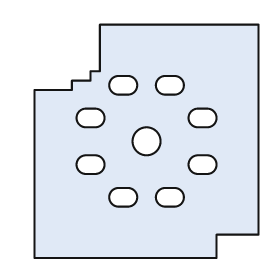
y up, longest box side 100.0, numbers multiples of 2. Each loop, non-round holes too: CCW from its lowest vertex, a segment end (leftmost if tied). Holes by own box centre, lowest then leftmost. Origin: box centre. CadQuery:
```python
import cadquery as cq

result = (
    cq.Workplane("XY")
    .moveTo(-48.0, -50.0)
    .lineTo(30.0, -50.0)
    .lineTo(30.0, -40.0)
    .lineTo(48.0, -40.0)
    .lineTo(48.0, 50.0)
    .lineTo(-20.0, 50.0)
    .lineTo(-20.0, 30.0)
    .lineTo(-24.0, 30.0)
    .lineTo(-24.0, 26.0)
    .lineTo(-32.0, 26.0)
    .lineTo(-32.0, 22.0)
    .lineTo(-48.0, 22.0)
    .close()
    .moveTo(-12.0, -28.0)
    .lineTo(-8.0, -28.0)
    .threePointArc((-4.0, -24.0), (-8.0, -20.0))
    .lineTo(-12.0, -20.0)
    .threePointArc((-16.0, -24.0), (-12.0, -28.0))
    .close()
    .moveTo(8.0, -28.0)
    .lineTo(12.0, -28.0)
    .threePointArc((16.0, -24.0), (12.0, -20.0))
    .lineTo(8.0, -20.0)
    .threePointArc((4.0, -24.0), (8.0, -28.0))
    .close()
    .moveTo(-26.0, -14.0)
    .lineTo(-22.0, -14.0)
    .threePointArc((-18.0, -10.0), (-22.0, -6.0))
    .lineTo(-26.0, -6.0)
    .threePointArc((-30.0, -10.0), (-26.0, -14.0))
    .close()
    .moveTo(22.0, -14.0)
    .lineTo(26.0, -14.0)
    .threePointArc((30.0, -10.0), (26.0, -6.0))
    .lineTo(22.0, -6.0)
    .threePointArc((18.0, -10.0), (22.0, -14.0))
    .close()
    .moveTo(0.0, 0.0)
    .circle(6.0)
    .moveTo(-26.0, 6.0)
    .lineTo(-22.0, 6.0)
    .threePointArc((-18.0, 10.0), (-22.0, 14.0))
    .lineTo(-26.0, 14.0)
    .threePointArc((-30.0, 10.0), (-26.0, 6.0))
    .close()
    .moveTo(22.0, 6.0)
    .lineTo(26.0, 6.0)
    .threePointArc((30.0, 10.0), (26.0, 14.0))
    .lineTo(22.0, 14.0)
    .threePointArc((18.0, 10.0), (22.0, 6.0))
    .close()
    .moveTo(-12.0, 20.0)
    .lineTo(-8.0, 20.0)
    .threePointArc((-4.0, 24.0), (-8.0, 28.0))
    .lineTo(-12.0, 28.0)
    .threePointArc((-16.0, 24.0), (-12.0, 20.0))
    .close()
    .moveTo(8.0, 20.0)
    .lineTo(12.0, 20.0)
    .threePointArc((16.0, 24.0), (12.0, 28.0))
    .lineTo(8.0, 28.0)
    .threePointArc((4.0, 24.0), (8.0, 20.0))
    .close()
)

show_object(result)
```